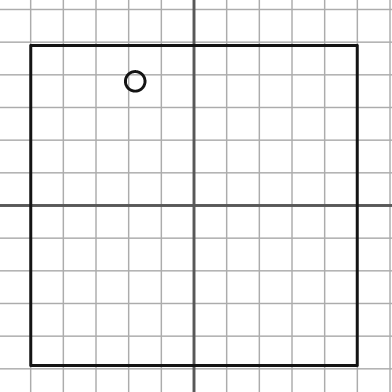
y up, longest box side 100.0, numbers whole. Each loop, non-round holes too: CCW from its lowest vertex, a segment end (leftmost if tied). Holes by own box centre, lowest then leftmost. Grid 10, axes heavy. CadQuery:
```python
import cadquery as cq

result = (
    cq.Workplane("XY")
    .moveTo(-50.0, -49.0)
    .lineTo(50.0, -49.0)
    .lineTo(50.0, 49.0)
    .lineTo(-50.0, 49.0)
    .close()
    .moveTo(-18.0, 38.0)
    .circle(3.0)
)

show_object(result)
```